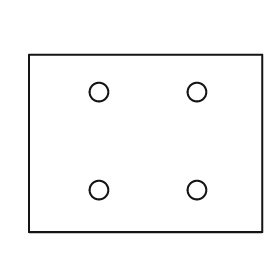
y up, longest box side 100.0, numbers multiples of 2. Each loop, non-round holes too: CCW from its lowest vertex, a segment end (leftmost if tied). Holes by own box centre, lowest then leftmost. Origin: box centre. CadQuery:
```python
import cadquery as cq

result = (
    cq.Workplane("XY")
    .moveTo(-50.0, -38.0)
    .lineTo(50.0, -38.0)
    .lineTo(50.0, 38.0)
    .lineTo(-50.0, 38.0)
    .close()
    .moveTo(-20.0, -20.0)
    .circle(4.0)
    .moveTo(22.0, -20.0)
    .circle(4.0)
    .moveTo(-20.0, 22.0)
    .circle(4.0)
    .moveTo(22.0, 22.0)
    .circle(4.0)
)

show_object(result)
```